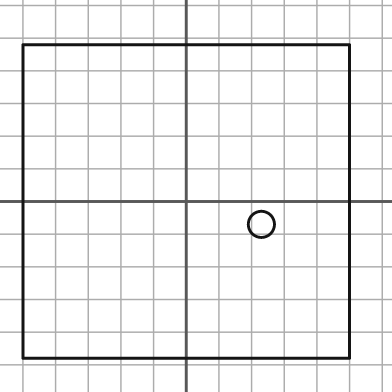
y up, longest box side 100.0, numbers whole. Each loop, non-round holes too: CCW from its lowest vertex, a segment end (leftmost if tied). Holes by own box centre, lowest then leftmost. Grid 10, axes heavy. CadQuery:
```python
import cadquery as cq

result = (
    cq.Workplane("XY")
    .moveTo(-50.0, -48.0)
    .lineTo(50.0, -48.0)
    .lineTo(50.0, 48.0)
    .lineTo(-50.0, 48.0)
    .close()
    .moveTo(23.0, -7.0)
    .circle(4.0)
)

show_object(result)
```